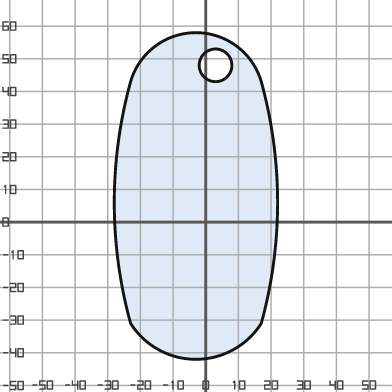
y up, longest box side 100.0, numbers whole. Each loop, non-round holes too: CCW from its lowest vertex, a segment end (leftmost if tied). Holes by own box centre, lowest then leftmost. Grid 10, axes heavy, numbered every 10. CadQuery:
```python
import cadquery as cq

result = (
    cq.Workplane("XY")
    .moveTo(-23.0, -31.0)
    .threePointArc((-3.0, -42.0), (17.0, -31.0))
    .threePointArc((22.0, 6.0), (17.0, 43.0))
    .threePointArc((-3.0, 58.0), (-23.0, 43.0))
    .threePointArc((-28.0, 6.0), (-23.0, -31.0))
    .close()
    .moveTo(3.0, 48.0)
    .circle(5.0)
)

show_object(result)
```